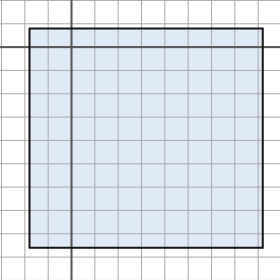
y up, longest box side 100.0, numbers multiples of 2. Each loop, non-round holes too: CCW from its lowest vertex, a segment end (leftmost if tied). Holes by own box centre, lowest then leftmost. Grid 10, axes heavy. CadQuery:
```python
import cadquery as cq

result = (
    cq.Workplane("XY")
    .moveTo(-18.0, -86.0)
    .lineTo(82.0, -86.0)
    .lineTo(82.0, 8.0)
    .lineTo(-18.0, 8.0)
    .close()
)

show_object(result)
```